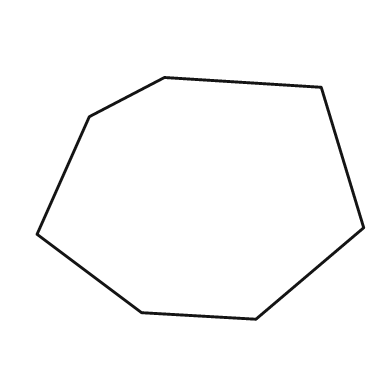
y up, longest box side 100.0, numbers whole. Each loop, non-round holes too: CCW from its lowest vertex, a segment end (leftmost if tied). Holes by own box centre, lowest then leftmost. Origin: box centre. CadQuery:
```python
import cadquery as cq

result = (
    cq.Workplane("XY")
    .moveTo(17.0, -37.0)
    .lineTo(50.0, -9.0)
    .lineTo(37.0, 34.0)
    .lineTo(-11.0, 37.0)
    .lineTo(-34.0, 25.0)
    .lineTo(-50.0, -11.0)
    .lineTo(-18.0, -35.0)
    .close()
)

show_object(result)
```